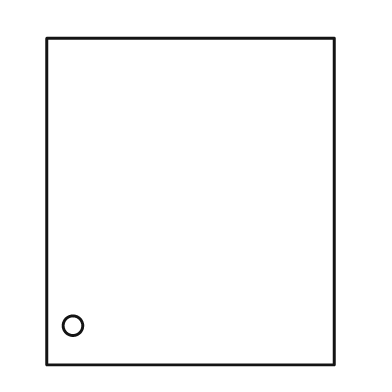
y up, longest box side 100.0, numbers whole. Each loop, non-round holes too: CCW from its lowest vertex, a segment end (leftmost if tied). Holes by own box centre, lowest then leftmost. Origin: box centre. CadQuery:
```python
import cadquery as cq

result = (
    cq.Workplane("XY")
    .moveTo(-44.0, -50.0)
    .lineTo(44.0, -50.0)
    .lineTo(44.0, 50.0)
    .lineTo(-44.0, 50.0)
    .close()
    .moveTo(-36.0, -38.0)
    .circle(3.0)
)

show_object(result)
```